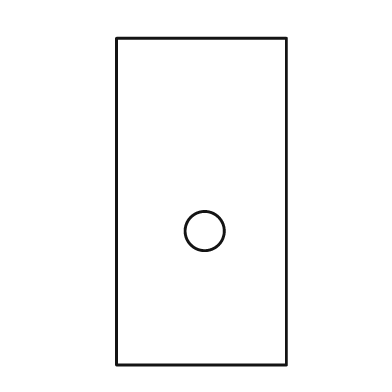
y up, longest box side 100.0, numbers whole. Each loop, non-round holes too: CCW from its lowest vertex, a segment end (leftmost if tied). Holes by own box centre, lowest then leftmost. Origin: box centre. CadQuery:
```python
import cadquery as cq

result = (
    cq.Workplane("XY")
    .moveTo(-26.0, -50.0)
    .lineTo(26.0, -50.0)
    .lineTo(26.0, 50.0)
    .lineTo(-26.0, 50.0)
    .close()
    .moveTo(1.0, -9.0)
    .circle(6.0)
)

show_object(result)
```